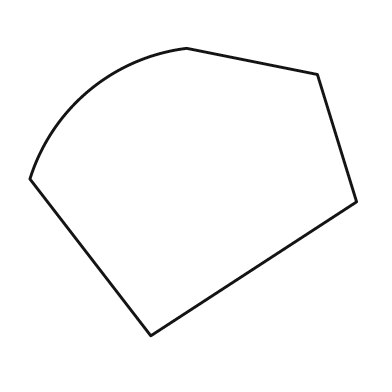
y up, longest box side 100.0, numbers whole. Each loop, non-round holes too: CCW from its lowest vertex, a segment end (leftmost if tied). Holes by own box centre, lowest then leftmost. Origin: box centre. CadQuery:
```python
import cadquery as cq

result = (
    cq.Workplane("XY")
    .moveTo(-13.0, -44.0)
    .lineTo(50.0, -3.0)
    .lineTo(38.0, 36.0)
    .lineTo(-2.0, 44.0)
    .threePointArc((-32.0, 31.0), (-50.0, 4.0))
    .close()
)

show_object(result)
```